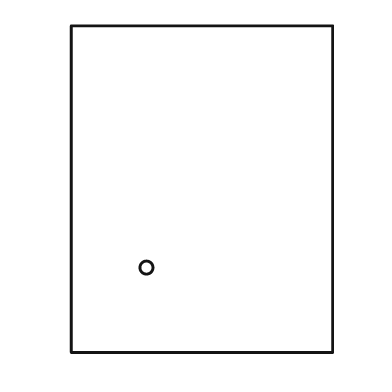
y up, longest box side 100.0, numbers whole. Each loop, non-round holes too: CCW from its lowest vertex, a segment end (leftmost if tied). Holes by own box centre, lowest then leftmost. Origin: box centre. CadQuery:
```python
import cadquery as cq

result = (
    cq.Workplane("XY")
    .moveTo(-40.0, -50.0)
    .lineTo(40.0, -50.0)
    .lineTo(40.0, 50.0)
    .lineTo(-40.0, 50.0)
    .close()
    .moveTo(-17.0, -24.0)
    .circle(2.0)
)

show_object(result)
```